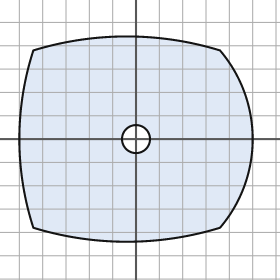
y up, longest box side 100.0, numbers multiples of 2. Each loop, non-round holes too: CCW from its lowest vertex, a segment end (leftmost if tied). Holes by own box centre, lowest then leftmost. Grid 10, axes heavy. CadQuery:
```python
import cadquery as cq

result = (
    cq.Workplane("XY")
    .moveTo(-44.0, -38.0)
    .threePointArc((-4.0, -44.0), (36.0, -38.0))
    .threePointArc((50.0, 0.0), (36.0, 38.0))
    .threePointArc((-4.0, 44.0), (-44.0, 38.0))
    .threePointArc((-50.0, 0.0), (-44.0, -38.0))
    .close()
    .moveTo(0.0, 0.0)
    .circle(6.0)
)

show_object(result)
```